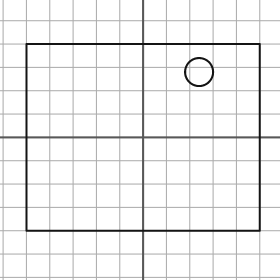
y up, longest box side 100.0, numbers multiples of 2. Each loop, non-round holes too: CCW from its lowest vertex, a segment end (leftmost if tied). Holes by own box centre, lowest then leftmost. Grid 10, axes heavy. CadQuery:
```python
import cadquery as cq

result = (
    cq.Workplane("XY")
    .moveTo(-50.0, -40.0)
    .lineTo(50.0, -40.0)
    .lineTo(50.0, 40.0)
    .lineTo(-50.0, 40.0)
    .close()
    .moveTo(24.0, 28.0)
    .circle(6.0)
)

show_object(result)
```